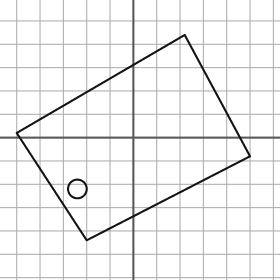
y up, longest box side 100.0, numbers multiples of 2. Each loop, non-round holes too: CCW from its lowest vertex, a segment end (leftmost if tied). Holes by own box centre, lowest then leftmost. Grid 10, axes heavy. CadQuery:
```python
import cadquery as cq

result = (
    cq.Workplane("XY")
    .moveTo(-20.0, -44.0)
    .lineTo(50.0, -8.0)
    .lineTo(22.0, 44.0)
    .lineTo(-50.0, 2.0)
    .close()
    .moveTo(-24.0, -22.0)
    .circle(4.0)
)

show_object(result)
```